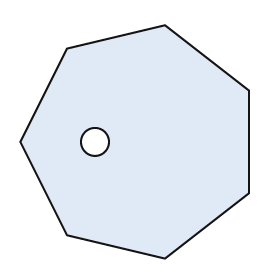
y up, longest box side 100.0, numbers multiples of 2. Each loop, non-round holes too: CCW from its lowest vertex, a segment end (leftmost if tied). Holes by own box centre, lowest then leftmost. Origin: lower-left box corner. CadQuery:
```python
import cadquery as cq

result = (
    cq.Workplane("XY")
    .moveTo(62.0, 0.0)
    .lineTo(98.0, 28.0)
    .lineTo(98.0, 72.0)
    .lineTo(62.0, 100.0)
    .lineTo(20.0, 90.0)
    .lineTo(0.0, 50.0)
    .lineTo(20.0, 10.0)
    .close()
    .moveTo(32.0, 50.0)
    .circle(6.0)
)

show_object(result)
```